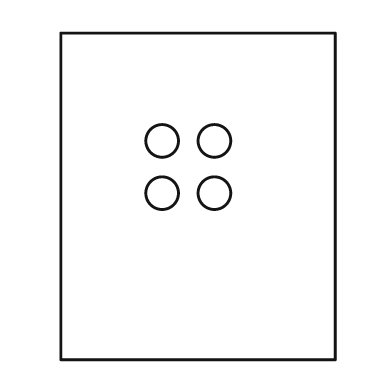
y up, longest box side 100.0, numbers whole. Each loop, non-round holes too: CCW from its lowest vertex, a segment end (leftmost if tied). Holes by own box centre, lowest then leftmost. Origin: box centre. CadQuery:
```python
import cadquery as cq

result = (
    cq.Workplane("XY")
    .moveTo(-42.0, -50.0)
    .lineTo(42.0, -50.0)
    .lineTo(42.0, 50.0)
    .lineTo(-42.0, 50.0)
    .close()
    .moveTo(-11.0, 1.0)
    .circle(5.0)
    .moveTo(5.0, 1.0)
    .circle(5.0)
    .moveTo(-11.0, 17.0)
    .circle(5.0)
    .moveTo(5.0, 17.0)
    .circle(5.0)
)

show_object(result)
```